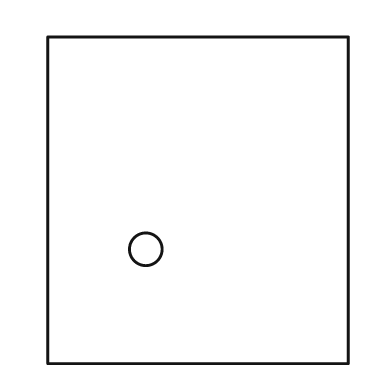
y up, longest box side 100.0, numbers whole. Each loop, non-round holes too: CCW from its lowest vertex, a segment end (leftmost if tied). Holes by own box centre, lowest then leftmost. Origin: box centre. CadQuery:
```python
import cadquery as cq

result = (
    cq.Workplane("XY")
    .moveTo(-46.0, -50.0)
    .lineTo(46.0, -50.0)
    .lineTo(46.0, 50.0)
    .lineTo(-46.0, 50.0)
    .close()
    .moveTo(-16.0, -15.0)
    .circle(5.0)
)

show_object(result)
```